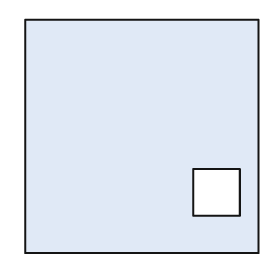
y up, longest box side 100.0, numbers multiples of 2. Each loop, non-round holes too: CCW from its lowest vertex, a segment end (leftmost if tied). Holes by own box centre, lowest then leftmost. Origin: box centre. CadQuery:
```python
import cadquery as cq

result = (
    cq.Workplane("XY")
    .moveTo(-50.0, -50.0)
    .lineTo(50.0, -50.0)
    .lineTo(50.0, 50.0)
    .lineTo(-50.0, 50.0)
    .close()
    .moveTo(22.0, -34.0)
    .lineTo(42.0, -34.0)
    .lineTo(42.0, -14.0)
    .lineTo(22.0, -14.0)
    .close()
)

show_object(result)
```